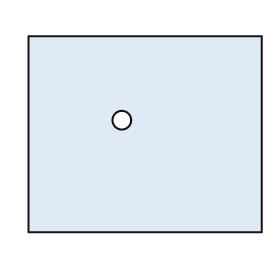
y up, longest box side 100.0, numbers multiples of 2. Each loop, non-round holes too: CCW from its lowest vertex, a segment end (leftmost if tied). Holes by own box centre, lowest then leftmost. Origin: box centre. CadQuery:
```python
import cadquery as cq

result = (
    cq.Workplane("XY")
    .moveTo(-50.0, -42.0)
    .lineTo(50.0, -42.0)
    .lineTo(50.0, 42.0)
    .lineTo(-50.0, 42.0)
    .close()
    .moveTo(-10.0, 6.0)
    .circle(4.0)
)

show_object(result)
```